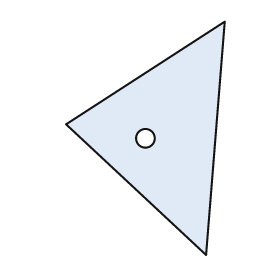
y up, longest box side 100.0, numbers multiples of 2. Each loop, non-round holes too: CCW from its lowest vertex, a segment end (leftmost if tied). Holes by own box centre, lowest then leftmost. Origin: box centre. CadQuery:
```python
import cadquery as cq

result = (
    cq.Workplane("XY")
    .moveTo(26.0, -50.0)
    .lineTo(34.0, 50.0)
    .lineTo(-34.0, 6.0)
    .close()
    .moveTo(0.0, 0.0)
    .circle(4.0)
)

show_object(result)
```